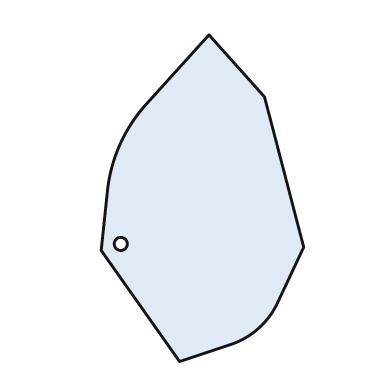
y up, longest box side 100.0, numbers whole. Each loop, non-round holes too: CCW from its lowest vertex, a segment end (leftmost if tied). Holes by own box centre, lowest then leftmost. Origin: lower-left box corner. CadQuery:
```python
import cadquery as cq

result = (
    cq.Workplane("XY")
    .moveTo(24.0, 0.0)
    .lineTo(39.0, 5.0)
    .threePointArc((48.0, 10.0), (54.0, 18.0))
    .lineTo(62.0, 35.0)
    .lineTo(50.0, 81.0)
    .lineTo(33.0, 100.0)
    .lineTo(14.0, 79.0)
    .threePointArc((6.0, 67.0), (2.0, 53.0))
    .lineTo(0.0, 34.0)
    .close()
    .moveTo(6.0, 36.0)
    .circle(2.0)
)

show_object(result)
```